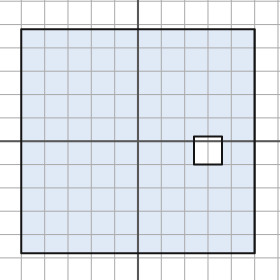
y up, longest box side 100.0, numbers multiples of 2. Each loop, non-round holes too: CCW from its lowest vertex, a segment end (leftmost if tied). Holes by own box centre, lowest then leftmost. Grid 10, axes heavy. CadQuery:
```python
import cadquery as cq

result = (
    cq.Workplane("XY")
    .moveTo(-50.0, -48.0)
    .lineTo(50.0, -48.0)
    .lineTo(50.0, 48.0)
    .lineTo(-50.0, 48.0)
    .close()
    .moveTo(24.0, -10.0)
    .lineTo(36.0, -10.0)
    .lineTo(36.0, 2.0)
    .lineTo(24.0, 2.0)
    .close()
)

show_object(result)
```